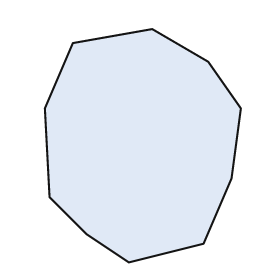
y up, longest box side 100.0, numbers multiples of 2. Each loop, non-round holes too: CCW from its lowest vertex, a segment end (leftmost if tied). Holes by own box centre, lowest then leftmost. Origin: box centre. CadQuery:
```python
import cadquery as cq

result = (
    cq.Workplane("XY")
    .moveTo(-6.0, -50.0)
    .lineTo(26.0, -42.0)
    .lineTo(38.0, -14.0)
    .lineTo(42.0, 16.0)
    .lineTo(28.0, 36.0)
    .lineTo(4.0, 50.0)
    .lineTo(-30.0, 44.0)
    .lineTo(-42.0, 16.0)
    .lineTo(-40.0, -22.0)
    .lineTo(-24.0, -38.0)
    .close()
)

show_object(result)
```